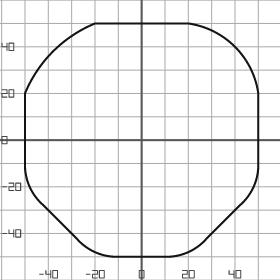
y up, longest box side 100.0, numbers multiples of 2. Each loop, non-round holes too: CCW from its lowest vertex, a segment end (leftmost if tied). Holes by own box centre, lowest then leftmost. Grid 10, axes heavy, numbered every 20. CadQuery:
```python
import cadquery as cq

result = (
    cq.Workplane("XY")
    .moveTo(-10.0, -50.0)
    .lineTo(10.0, -50.0)
    .threePointArc((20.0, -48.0), (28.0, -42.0))
    .lineTo(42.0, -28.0)
    .threePointArc((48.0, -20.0), (50.0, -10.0))
    .lineTo(50.0, 20.0)
    .threePointArc((40.0, 40.0), (20.0, 50.0))
    .lineTo(-20.0, 50.0)
    .threePointArc((-38.0, 38.0), (-50.0, 20.0))
    .lineTo(-50.0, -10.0)
    .threePointArc((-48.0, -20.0), (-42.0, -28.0))
    .lineTo(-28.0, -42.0)
    .threePointArc((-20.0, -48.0), (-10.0, -50.0))
    .close()
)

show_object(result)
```